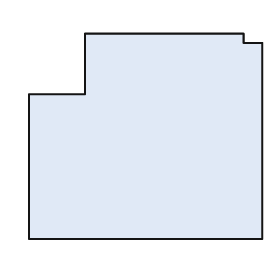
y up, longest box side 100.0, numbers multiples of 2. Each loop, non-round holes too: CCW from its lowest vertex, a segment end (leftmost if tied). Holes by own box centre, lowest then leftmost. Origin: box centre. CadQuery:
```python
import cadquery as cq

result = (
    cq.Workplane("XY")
    .moveTo(-50.0, -44.0)
    .lineTo(50.0, -44.0)
    .lineTo(50.0, 40.0)
    .lineTo(42.0, 40.0)
    .lineTo(42.0, 44.0)
    .lineTo(-26.0, 44.0)
    .lineTo(-26.0, 18.0)
    .lineTo(-50.0, 18.0)
    .close()
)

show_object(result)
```